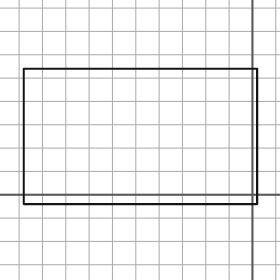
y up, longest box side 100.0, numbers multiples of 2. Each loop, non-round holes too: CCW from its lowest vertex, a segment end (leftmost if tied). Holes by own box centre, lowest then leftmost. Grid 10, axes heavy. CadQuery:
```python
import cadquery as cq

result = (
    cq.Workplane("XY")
    .moveTo(-98.0, -4.0)
    .lineTo(2.0, -4.0)
    .lineTo(2.0, 54.0)
    .lineTo(-98.0, 54.0)
    .close()
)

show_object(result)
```